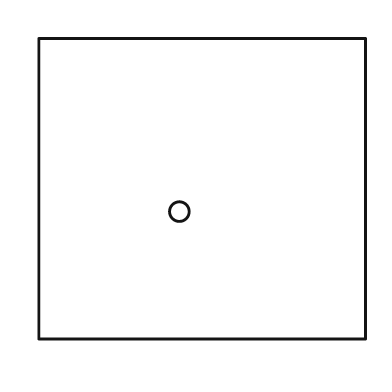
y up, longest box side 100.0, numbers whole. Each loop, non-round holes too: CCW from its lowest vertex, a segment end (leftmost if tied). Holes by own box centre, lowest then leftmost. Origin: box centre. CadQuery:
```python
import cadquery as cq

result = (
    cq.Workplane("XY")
    .moveTo(-50.0, -46.0)
    .lineTo(50.0, -46.0)
    .lineTo(50.0, 46.0)
    .lineTo(-50.0, 46.0)
    .close()
    .moveTo(-7.0, -7.0)
    .circle(3.0)
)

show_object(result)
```